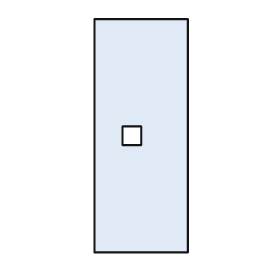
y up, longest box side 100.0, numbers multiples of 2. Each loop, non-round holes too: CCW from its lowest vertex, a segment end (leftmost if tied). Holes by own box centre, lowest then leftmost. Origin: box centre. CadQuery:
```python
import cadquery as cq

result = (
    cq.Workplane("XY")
    .moveTo(-20.0, -50.0)
    .lineTo(20.0, -50.0)
    .lineTo(20.0, 50.0)
    .lineTo(-20.0, 50.0)
    .close()
    .moveTo(-8.0, -4.0)
    .lineTo(0.0, -4.0)
    .lineTo(0.0, 4.0)
    .lineTo(-8.0, 4.0)
    .close()
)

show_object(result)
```